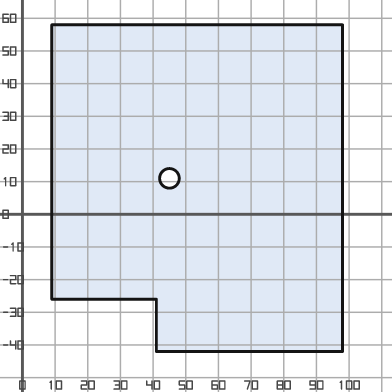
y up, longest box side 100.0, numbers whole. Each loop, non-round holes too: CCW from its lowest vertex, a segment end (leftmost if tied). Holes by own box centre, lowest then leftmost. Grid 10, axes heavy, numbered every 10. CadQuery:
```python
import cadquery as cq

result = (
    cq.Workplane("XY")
    .moveTo(41.0, -42.0)
    .lineTo(98.0, -42.0)
    .lineTo(98.0, 58.0)
    .lineTo(9.0, 58.0)
    .lineTo(9.0, -26.0)
    .lineTo(41.0, -26.0)
    .close()
    .moveTo(45.0, 11.0)
    .circle(3.0)
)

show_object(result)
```